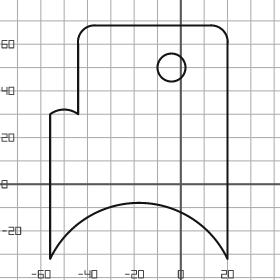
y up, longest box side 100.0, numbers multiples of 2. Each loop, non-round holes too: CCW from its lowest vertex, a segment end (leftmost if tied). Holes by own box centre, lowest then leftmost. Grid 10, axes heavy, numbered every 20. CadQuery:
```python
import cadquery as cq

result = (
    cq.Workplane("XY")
    .moveTo(-56.0, -32.0)
    .threePointArc((-18.0, -8.0), (20.0, -32.0))
    .lineTo(20.0, 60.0)
    .threePointArc((18.0, 66.0), (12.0, 68.0))
    .lineTo(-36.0, 68.0)
    .threePointArc((-42.0, 66.0), (-44.0, 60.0))
    .lineTo(-44.0, 30.0)
    .threePointArc((-50.0, 32.0), (-56.0, 30.0))
    .close()
    .moveTo(-4.0, 50.0)
    .circle(6.0)
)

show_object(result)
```